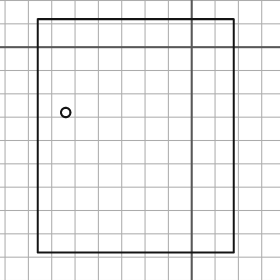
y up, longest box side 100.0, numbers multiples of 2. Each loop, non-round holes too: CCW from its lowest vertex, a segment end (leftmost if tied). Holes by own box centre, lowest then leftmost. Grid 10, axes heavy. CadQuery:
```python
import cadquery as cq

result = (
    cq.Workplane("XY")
    .moveTo(-66.0, -88.0)
    .lineTo(18.0, -88.0)
    .lineTo(18.0, 12.0)
    .lineTo(-66.0, 12.0)
    .close()
    .moveTo(-54.0, -28.0)
    .circle(2.0)
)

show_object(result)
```